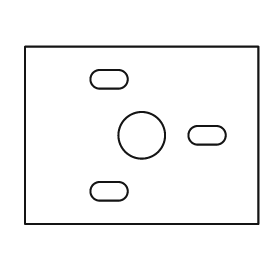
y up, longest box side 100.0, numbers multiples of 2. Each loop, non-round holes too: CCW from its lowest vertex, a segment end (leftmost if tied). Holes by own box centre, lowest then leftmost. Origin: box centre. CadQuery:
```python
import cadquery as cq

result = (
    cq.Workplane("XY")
    .moveTo(-50.0, -38.0)
    .lineTo(50.0, -38.0)
    .lineTo(50.0, 38.0)
    .lineTo(-50.0, 38.0)
    .close()
    .moveTo(-18.0, -28.0)
    .lineTo(-10.0, -28.0)
    .threePointArc((-6.0, -24.0), (-10.0, -20.0))
    .lineTo(-18.0, -20.0)
    .threePointArc((-22.0, -24.0), (-18.0, -28.0))
    .close()
    .moveTo(0.0, 0.0)
    .circle(10.0)
    .moveTo(24.0, -4.0)
    .lineTo(32.0, -4.0)
    .threePointArc((36.0, 0.0), (32.0, 4.0))
    .lineTo(24.0, 4.0)
    .threePointArc((20.0, 0.0), (24.0, -4.0))
    .close()
    .moveTo(-18.0, 20.0)
    .lineTo(-10.0, 20.0)
    .threePointArc((-6.0, 24.0), (-10.0, 28.0))
    .lineTo(-18.0, 28.0)
    .threePointArc((-22.0, 24.0), (-18.0, 20.0))
    .close()
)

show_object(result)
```